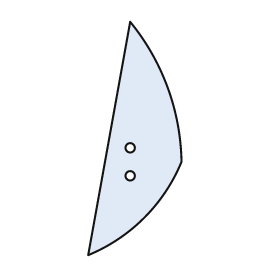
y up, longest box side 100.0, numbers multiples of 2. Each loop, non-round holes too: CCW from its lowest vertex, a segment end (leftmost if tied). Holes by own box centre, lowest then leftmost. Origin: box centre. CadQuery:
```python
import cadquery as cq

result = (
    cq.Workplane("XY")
    .moveTo(-20.0, -50.0)
    .threePointArc((4.0, -34.0), (20.0, -10.0))
    .threePointArc((14.0, 22.0), (-2.0, 50.0))
    .close()
    .moveTo(-2.0, -16.0)
    .circle(2.0)
    .moveTo(-2.0, -4.0)
    .circle(2.0)
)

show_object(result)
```